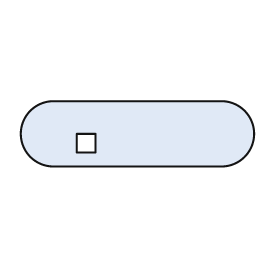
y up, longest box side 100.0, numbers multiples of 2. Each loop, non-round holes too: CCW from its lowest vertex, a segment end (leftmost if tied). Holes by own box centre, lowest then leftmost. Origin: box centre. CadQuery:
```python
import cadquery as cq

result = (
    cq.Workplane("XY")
    .moveTo(-36.0, -14.0)
    .lineTo(36.0, -14.0)
    .threePointArc((50.0, 0.0), (36.0, 14.0))
    .lineTo(-36.0, 14.0)
    .threePointArc((-50.0, 0.0), (-36.0, -14.0))
    .close()
    .moveTo(-26.0, -8.0)
    .lineTo(-18.0, -8.0)
    .lineTo(-18.0, 0.0)
    .lineTo(-26.0, 0.0)
    .close()
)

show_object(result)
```